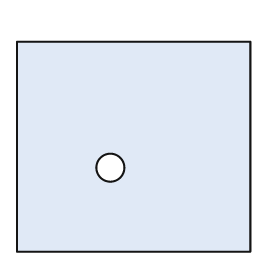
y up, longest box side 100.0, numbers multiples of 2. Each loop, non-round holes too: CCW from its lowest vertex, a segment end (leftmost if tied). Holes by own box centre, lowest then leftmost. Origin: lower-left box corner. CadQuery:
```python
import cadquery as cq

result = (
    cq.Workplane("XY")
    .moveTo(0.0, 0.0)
    .lineTo(100.0, 0.0)
    .lineTo(100.0, 90.0)
    .lineTo(0.0, 90.0)
    .close()
    .moveTo(40.0, 36.0)
    .circle(6.0)
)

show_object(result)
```